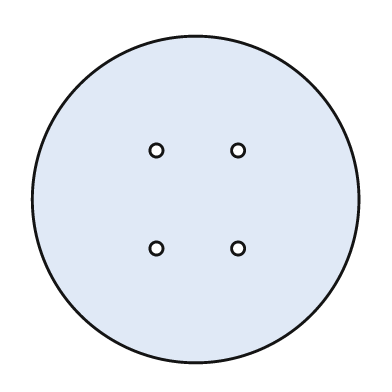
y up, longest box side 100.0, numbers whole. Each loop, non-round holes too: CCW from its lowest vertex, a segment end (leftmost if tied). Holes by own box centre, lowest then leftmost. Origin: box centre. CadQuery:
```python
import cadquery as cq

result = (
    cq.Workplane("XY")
    .moveTo(0.0, 0.0)
    .circle(50.0)
    .moveTo(-12.0, -15.0)
    .circle(2.0)
    .moveTo(13.0, -15.0)
    .circle(2.0)
    .moveTo(-12.0, 15.0)
    .circle(2.0)
    .moveTo(13.0, 15.0)
    .circle(2.0)
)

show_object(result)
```